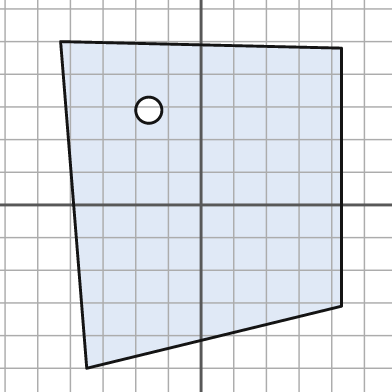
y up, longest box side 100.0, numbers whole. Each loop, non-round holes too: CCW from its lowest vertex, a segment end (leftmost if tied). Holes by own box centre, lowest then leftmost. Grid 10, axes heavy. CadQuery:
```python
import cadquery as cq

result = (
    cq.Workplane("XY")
    .moveTo(-35.0, -50.0)
    .lineTo(43.0, -31.0)
    .lineTo(43.0, 48.0)
    .lineTo(-43.0, 50.0)
    .close()
    .moveTo(-16.0, 29.0)
    .circle(4.0)
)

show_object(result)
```